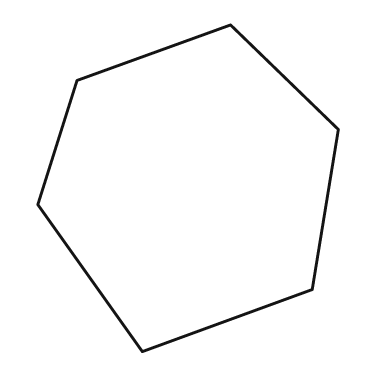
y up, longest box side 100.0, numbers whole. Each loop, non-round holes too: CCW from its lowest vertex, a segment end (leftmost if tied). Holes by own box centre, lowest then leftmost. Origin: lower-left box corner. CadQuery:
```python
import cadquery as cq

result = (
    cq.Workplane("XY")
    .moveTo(32.0, 0.0)
    .lineTo(84.0, 19.0)
    .lineTo(92.0, 68.0)
    .lineTo(59.0, 100.0)
    .lineTo(12.0, 83.0)
    .lineTo(0.0, 45.0)
    .close()
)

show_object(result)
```